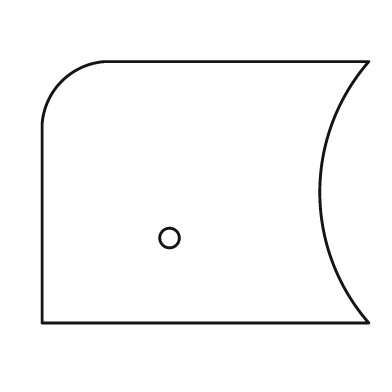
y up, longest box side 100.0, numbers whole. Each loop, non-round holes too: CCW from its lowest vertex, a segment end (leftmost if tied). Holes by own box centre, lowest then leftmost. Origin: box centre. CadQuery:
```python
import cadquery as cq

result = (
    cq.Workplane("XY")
    .moveTo(-50.0, -40.0)
    .lineTo(50.0, -40.0)
    .threePointArc((35.0, 0.0), (50.0, 40.0))
    .lineTo(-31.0, 40.0)
    .threePointArc((-44.0, 34.0), (-50.0, 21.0))
    .close()
    .moveTo(-11.0, -14.0)
    .circle(3.0)
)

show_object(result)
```